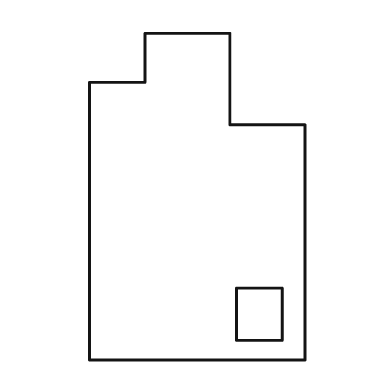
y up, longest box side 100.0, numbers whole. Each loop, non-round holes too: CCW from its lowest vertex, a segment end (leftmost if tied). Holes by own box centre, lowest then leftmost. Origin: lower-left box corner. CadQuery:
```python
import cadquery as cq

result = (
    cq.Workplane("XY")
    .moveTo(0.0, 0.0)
    .lineTo(66.0, 0.0)
    .lineTo(66.0, 72.0)
    .lineTo(43.0, 72.0)
    .lineTo(43.0, 100.0)
    .lineTo(17.0, 100.0)
    .lineTo(17.0, 85.0)
    .lineTo(0.0, 85.0)
    .close()
    .moveTo(45.0, 6.0)
    .lineTo(59.0, 6.0)
    .lineTo(59.0, 22.0)
    .lineTo(45.0, 22.0)
    .close()
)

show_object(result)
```